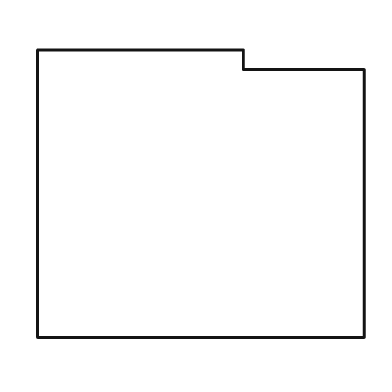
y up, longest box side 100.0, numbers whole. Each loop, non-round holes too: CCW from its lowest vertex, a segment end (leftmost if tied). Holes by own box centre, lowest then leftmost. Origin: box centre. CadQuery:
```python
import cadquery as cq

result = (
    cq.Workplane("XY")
    .moveTo(-50.0, -44.0)
    .lineTo(50.0, -44.0)
    .lineTo(50.0, 38.0)
    .lineTo(13.0, 38.0)
    .lineTo(13.0, 44.0)
    .lineTo(-50.0, 44.0)
    .close()
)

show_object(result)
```